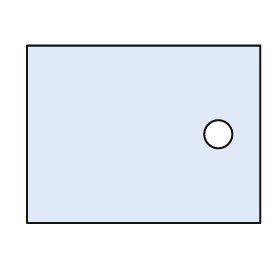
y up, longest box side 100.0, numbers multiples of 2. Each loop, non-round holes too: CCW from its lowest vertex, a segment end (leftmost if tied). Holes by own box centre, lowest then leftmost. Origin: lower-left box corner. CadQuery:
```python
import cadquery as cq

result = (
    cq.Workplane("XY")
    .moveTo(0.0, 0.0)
    .lineTo(100.0, 0.0)
    .lineTo(100.0, 76.0)
    .lineTo(0.0, 76.0)
    .close()
    .moveTo(82.0, 38.0)
    .circle(6.0)
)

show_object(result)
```